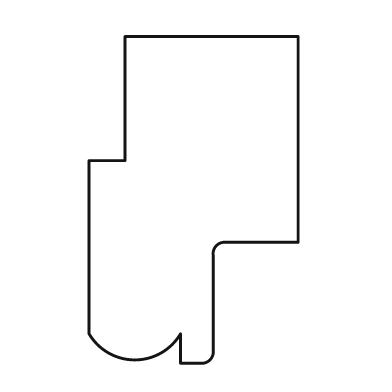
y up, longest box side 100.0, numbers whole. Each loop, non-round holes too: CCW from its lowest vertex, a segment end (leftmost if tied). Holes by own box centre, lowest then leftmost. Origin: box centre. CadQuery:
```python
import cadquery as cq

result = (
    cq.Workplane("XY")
    .moveTo(-4.0, -50.0)
    .lineTo(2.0, -50.0)
    .threePointArc((5.0, -49.0), (6.0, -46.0))
    .lineTo(6.0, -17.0)
    .threePointArc((7.0, -14.0), (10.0, -13.0))
    .lineTo(32.0, -13.0)
    .lineTo(32.0, 50.0)
    .lineTo(-21.0, 50.0)
    .lineTo(-21.0, 12.0)
    .lineTo(-32.0, 12.0)
    .lineTo(-32.0, -41.0)
    .threePointArc((-18.0, -49.0), (-4.0, -41.0))
    .close()
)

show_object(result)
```